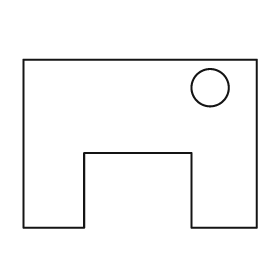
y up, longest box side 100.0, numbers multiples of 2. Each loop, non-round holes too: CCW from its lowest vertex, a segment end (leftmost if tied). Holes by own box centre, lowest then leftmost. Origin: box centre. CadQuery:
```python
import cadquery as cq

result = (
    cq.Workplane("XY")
    .moveTo(-50.0, -36.0)
    .lineTo(-24.0, -36.0)
    .lineTo(-24.0, -4.0)
    .lineTo(22.0, -4.0)
    .lineTo(22.0, -36.0)
    .lineTo(50.0, -36.0)
    .lineTo(50.0, 36.0)
    .lineTo(-50.0, 36.0)
    .close()
    .moveTo(30.0, 24.0)
    .circle(8.0)
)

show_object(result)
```